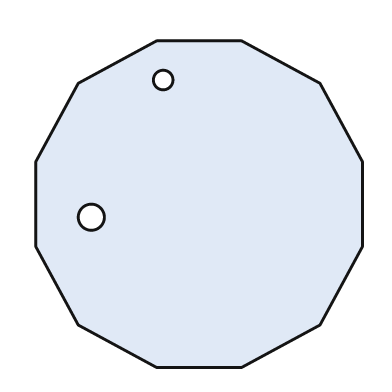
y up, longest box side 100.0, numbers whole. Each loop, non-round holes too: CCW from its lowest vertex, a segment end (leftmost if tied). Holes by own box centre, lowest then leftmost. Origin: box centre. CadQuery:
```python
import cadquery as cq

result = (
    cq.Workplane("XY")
    .moveTo(-13.0, -50.0)
    .lineTo(13.0, -50.0)
    .lineTo(37.0, -37.0)
    .lineTo(50.0, -13.0)
    .lineTo(50.0, 13.0)
    .lineTo(37.0, 37.0)
    .lineTo(13.0, 50.0)
    .lineTo(-13.0, 50.0)
    .lineTo(-37.0, 37.0)
    .lineTo(-50.0, 13.0)
    .lineTo(-50.0, -13.0)
    .lineTo(-37.0, -37.0)
    .close()
    .moveTo(-33.0, -4.0)
    .circle(4.0)
    .moveTo(-11.0, 38.0)
    .circle(3.0)
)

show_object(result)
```